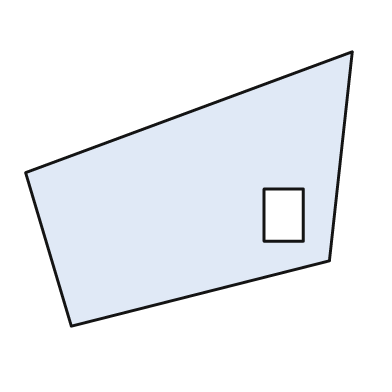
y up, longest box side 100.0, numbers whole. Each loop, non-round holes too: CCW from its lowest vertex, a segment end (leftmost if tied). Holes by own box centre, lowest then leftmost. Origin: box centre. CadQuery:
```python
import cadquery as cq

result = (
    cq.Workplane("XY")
    .moveTo(-36.0, -42.0)
    .lineTo(43.0, -22.0)
    .lineTo(50.0, 42.0)
    .lineTo(-50.0, 5.0)
    .close()
    .moveTo(23.0, -16.0)
    .lineTo(35.0, -16.0)
    .lineTo(35.0, 0.0)
    .lineTo(23.0, 0.0)
    .close()
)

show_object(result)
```